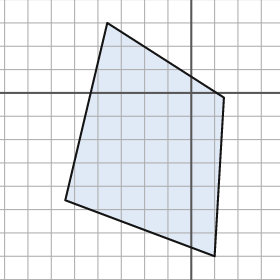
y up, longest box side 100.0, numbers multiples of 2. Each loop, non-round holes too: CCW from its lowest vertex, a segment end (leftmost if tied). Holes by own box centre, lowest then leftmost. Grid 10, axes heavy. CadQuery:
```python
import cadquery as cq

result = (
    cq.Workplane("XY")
    .moveTo(10.0, -70.0)
    .lineTo(14.0, -2.0)
    .lineTo(-36.0, 30.0)
    .lineTo(-54.0, -46.0)
    .close()
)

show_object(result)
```